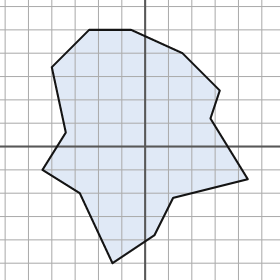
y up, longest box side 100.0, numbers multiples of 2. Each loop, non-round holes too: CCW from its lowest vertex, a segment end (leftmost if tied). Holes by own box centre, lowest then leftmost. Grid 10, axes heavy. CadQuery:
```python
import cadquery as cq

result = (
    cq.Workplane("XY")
    .moveTo(-14.0, -50.0)
    .lineTo(4.0, -38.0)
    .lineTo(12.0, -22.0)
    .lineTo(44.0, -14.0)
    .lineTo(28.0, 12.0)
    .lineTo(32.0, 24.0)
    .lineTo(16.0, 40.0)
    .lineTo(-6.0, 50.0)
    .lineTo(-24.0, 50.0)
    .lineTo(-40.0, 34.0)
    .lineTo(-34.0, 6.0)
    .lineTo(-44.0, -10.0)
    .lineTo(-28.0, -20.0)
    .close()
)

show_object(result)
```